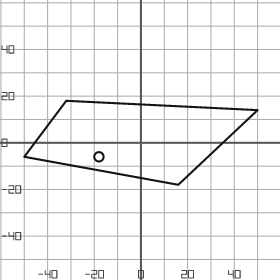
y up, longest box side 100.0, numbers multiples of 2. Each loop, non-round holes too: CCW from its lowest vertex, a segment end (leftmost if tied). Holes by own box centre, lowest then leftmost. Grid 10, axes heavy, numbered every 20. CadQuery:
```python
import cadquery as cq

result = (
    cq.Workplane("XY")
    .moveTo(16.0, -18.0)
    .lineTo(50.0, 14.0)
    .lineTo(-32.0, 18.0)
    .lineTo(-50.0, -6.0)
    .close()
    .moveTo(-18.0, -6.0)
    .circle(2.0)
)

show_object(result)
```